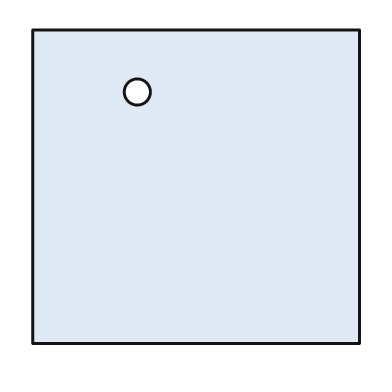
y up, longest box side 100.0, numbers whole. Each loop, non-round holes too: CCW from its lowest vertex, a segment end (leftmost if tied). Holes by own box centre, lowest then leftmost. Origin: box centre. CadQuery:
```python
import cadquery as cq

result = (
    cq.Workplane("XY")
    .moveTo(-50.0, -48.0)
    .lineTo(50.0, -48.0)
    .lineTo(50.0, 48.0)
    .lineTo(-50.0, 48.0)
    .close()
    .moveTo(-18.0, 29.0)
    .circle(4.0)
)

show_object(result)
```